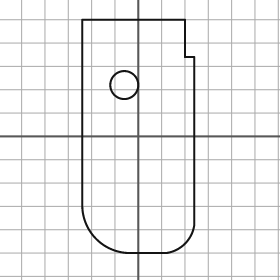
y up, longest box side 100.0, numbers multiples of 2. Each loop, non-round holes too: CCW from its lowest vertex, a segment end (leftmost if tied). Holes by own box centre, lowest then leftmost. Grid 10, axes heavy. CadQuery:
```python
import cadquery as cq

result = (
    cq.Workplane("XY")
    .moveTo(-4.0, -50.0)
    .lineTo(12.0, -50.0)
    .threePointArc((20.0, -46.0), (24.0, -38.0))
    .lineTo(24.0, 34.0)
    .lineTo(20.0, 34.0)
    .lineTo(20.0, 50.0)
    .lineTo(-24.0, 50.0)
    .lineTo(-24.0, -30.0)
    .threePointArc((-18.0, -44.0), (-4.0, -50.0))
    .close()
    .moveTo(-6.0, 22.0)
    .circle(6.0)
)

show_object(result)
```